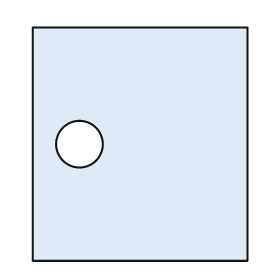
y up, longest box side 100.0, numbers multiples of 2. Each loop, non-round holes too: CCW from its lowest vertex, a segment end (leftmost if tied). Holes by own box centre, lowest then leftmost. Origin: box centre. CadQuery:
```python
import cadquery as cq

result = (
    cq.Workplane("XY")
    .moveTo(-46.0, -50.0)
    .lineTo(46.0, -50.0)
    .lineTo(46.0, 50.0)
    .lineTo(-46.0, 50.0)
    .close()
    .moveTo(-26.0, 0.0)
    .circle(10.0)
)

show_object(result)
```